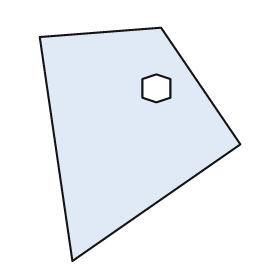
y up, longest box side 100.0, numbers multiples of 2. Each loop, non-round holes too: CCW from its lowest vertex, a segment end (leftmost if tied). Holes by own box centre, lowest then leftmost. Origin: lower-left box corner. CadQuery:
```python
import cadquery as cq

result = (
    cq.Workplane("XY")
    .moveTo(14.0, 0.0)
    .lineTo(86.0, 50.0)
    .lineTo(52.0, 100.0)
    .lineTo(0.0, 96.0)
    .close()
    .moveTo(50.0, 68.0)
    .lineTo(56.0, 70.0)
    .lineTo(56.0, 78.0)
    .lineTo(50.0, 80.0)
    .lineTo(44.0, 78.0)
    .lineTo(44.0, 70.0)
    .close()
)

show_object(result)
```